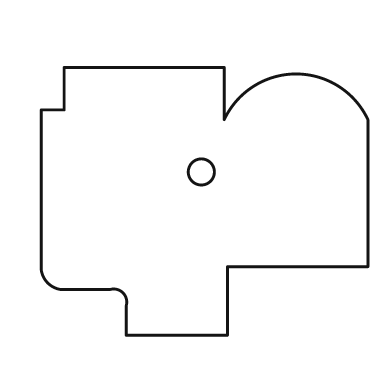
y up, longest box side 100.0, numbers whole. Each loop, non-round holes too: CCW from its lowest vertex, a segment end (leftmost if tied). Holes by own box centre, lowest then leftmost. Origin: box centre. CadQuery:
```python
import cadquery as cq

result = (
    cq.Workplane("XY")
    .moveTo(-24.0, -41.0)
    .lineTo(7.0, -41.0)
    .lineTo(7.0, -20.0)
    .lineTo(50.0, -20.0)
    .lineTo(50.0, 25.0)
    .threePointArc((28.0, 39.0), (6.0, 25.0))
    .lineTo(6.0, 41.0)
    .lineTo(-43.0, 41.0)
    .lineTo(-43.0, 28.0)
    .lineTo(-50.0, 28.0)
    .lineTo(-50.0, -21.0)
    .threePointArc((-48.0, -25.0), (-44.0, -27.0))
    .lineTo(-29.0, -27.0)
    .threePointArc((-25.0, -28.0), (-24.0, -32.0))
    .close()
    .moveTo(-1.0, 9.0)
    .circle(4.0)
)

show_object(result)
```